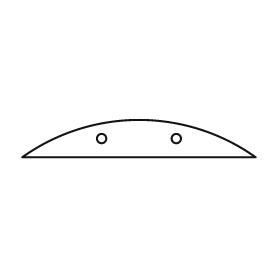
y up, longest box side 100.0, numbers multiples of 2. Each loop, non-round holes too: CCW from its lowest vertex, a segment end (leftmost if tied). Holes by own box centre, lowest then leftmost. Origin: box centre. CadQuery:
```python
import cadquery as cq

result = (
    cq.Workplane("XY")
    .moveTo(-50.0, -8.0)
    .lineTo(50.0, -8.0)
    .threePointArc((0.0, 8.0), (-50.0, -8.0))
    .close()
    .moveTo(-16.0, 0.0)
    .circle(2.0)
    .moveTo(16.0, 0.0)
    .circle(2.0)
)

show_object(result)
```